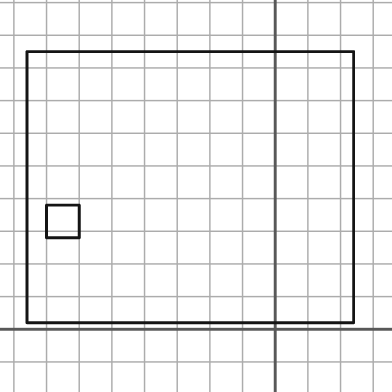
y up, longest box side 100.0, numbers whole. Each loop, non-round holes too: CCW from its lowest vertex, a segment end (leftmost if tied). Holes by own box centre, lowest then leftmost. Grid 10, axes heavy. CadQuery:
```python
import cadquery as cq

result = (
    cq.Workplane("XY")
    .moveTo(-76.0, 2.0)
    .lineTo(24.0, 2.0)
    .lineTo(24.0, 85.0)
    .lineTo(-76.0, 85.0)
    .close()
    .moveTo(-70.0, 28.0)
    .lineTo(-60.0, 28.0)
    .lineTo(-60.0, 38.0)
    .lineTo(-70.0, 38.0)
    .close()
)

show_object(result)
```